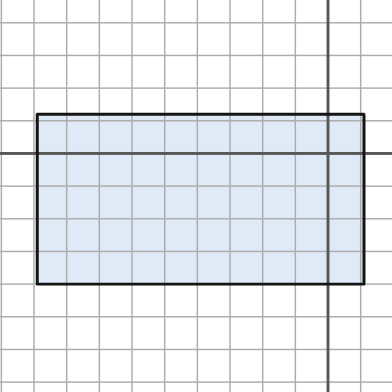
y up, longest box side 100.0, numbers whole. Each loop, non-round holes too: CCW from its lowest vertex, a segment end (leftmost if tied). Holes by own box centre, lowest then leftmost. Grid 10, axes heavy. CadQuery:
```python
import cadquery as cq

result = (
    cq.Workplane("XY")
    .moveTo(-89.0, -40.0)
    .lineTo(11.0, -40.0)
    .lineTo(11.0, 12.0)
    .lineTo(-89.0, 12.0)
    .close()
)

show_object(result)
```